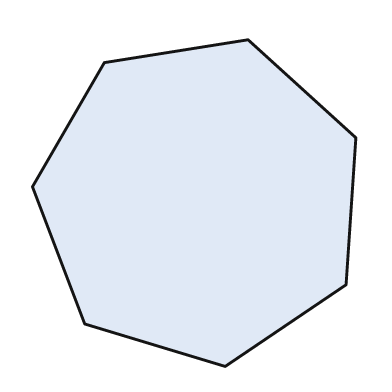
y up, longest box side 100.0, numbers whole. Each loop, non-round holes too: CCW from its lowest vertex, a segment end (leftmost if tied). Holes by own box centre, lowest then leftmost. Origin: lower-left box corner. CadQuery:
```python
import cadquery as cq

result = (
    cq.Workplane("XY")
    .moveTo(59.0, 0.0)
    .lineTo(96.0, 25.0)
    .lineTo(99.0, 70.0)
    .lineTo(66.0, 100.0)
    .lineTo(22.0, 93.0)
    .lineTo(0.0, 55.0)
    .lineTo(16.0, 13.0)
    .close()
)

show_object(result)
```